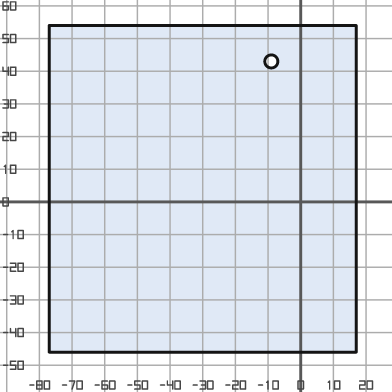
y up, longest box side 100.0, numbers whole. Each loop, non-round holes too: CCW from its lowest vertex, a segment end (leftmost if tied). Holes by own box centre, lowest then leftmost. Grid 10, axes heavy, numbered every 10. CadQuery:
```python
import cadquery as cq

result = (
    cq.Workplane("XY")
    .moveTo(-77.0, -46.0)
    .lineTo(17.0, -46.0)
    .lineTo(17.0, 54.0)
    .lineTo(-77.0, 54.0)
    .close()
    .moveTo(-9.0, 43.0)
    .circle(2.0)
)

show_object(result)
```